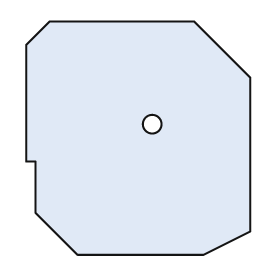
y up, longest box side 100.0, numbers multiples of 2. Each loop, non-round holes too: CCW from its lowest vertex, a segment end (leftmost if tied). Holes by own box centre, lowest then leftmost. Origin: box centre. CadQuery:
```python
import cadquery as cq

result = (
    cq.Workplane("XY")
    .moveTo(-26.0, -50.0)
    .lineTo(28.0, -50.0)
    .lineTo(48.0, -40.0)
    .lineTo(48.0, 26.0)
    .lineTo(24.0, 50.0)
    .lineTo(-38.0, 50.0)
    .lineTo(-48.0, 40.0)
    .lineTo(-48.0, -10.0)
    .lineTo(-44.0, -10.0)
    .lineTo(-44.0, -32.0)
    .close()
    .moveTo(6.0, 6.0)
    .circle(4.0)
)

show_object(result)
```